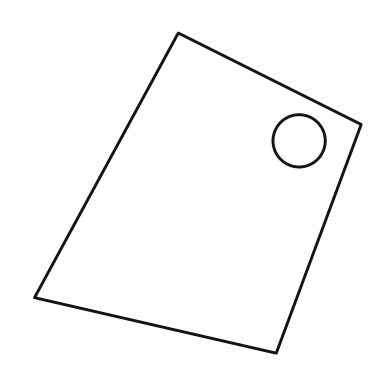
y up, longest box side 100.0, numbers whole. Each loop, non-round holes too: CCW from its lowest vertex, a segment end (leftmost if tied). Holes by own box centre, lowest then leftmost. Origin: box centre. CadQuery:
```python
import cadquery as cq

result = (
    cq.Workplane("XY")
    .moveTo(24.0, -49.0)
    .lineTo(50.0, 21.0)
    .lineTo(-6.0, 49.0)
    .lineTo(-50.0, -32.0)
    .close()
    .moveTo(31.0, 16.0)
    .circle(8.0)
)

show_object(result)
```